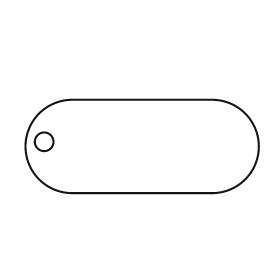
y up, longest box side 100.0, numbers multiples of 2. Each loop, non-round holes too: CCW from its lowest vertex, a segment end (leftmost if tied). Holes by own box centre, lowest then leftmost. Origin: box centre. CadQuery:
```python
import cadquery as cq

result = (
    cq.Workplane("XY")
    .moveTo(-30.0, -20.0)
    .lineTo(30.0, -20.0)
    .threePointArc((50.0, 0.0), (30.0, 20.0))
    .lineTo(-30.0, 20.0)
    .threePointArc((-50.0, 0.0), (-30.0, -20.0))
    .close()
    .moveTo(-42.0, 2.0)
    .circle(4.0)
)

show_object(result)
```